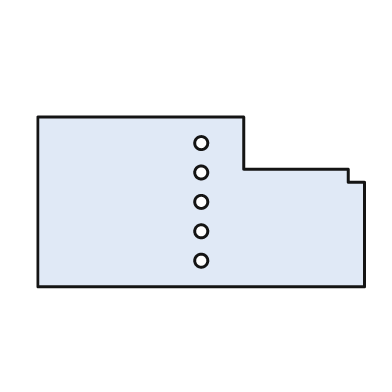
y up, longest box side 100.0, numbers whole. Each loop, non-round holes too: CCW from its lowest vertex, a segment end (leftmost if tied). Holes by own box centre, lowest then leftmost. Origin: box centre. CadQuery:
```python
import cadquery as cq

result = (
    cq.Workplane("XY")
    .moveTo(-50.0, -26.0)
    .lineTo(50.0, -26.0)
    .lineTo(50.0, 6.0)
    .lineTo(45.0, 6.0)
    .lineTo(45.0, 10.0)
    .lineTo(13.0, 10.0)
    .lineTo(13.0, 26.0)
    .lineTo(-50.0, 26.0)
    .close()
    .moveTo(0.0, -18.0)
    .circle(2.0)
    .moveTo(0.0, -9.0)
    .circle(2.0)
    .moveTo(0.0, 0.0)
    .circle(2.0)
    .moveTo(0.0, 9.0)
    .circle(2.0)
    .moveTo(0.0, 18.0)
    .circle(2.0)
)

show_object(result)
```